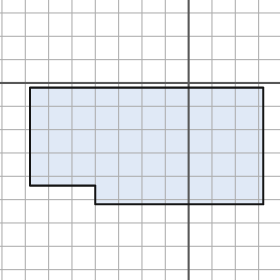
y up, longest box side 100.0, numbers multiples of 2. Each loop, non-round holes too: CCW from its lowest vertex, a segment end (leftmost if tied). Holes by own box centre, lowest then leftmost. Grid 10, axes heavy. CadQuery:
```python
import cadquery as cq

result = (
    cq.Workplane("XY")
    .moveTo(-40.0, -52.0)
    .lineTo(32.0, -52.0)
    .lineTo(32.0, -2.0)
    .lineTo(-68.0, -2.0)
    .lineTo(-68.0, -44.0)
    .lineTo(-40.0, -44.0)
    .close()
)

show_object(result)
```